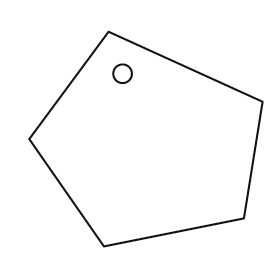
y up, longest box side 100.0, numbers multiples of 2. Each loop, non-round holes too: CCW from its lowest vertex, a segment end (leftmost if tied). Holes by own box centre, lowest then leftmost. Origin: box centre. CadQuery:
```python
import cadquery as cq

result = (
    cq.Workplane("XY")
    .moveTo(-18.0, -46.0)
    .lineTo(42.0, -34.0)
    .lineTo(50.0, 16.0)
    .lineTo(-16.0, 46.0)
    .lineTo(-50.0, 0.0)
    .close()
    .moveTo(-10.0, 28.0)
    .circle(4.0)
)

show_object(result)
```